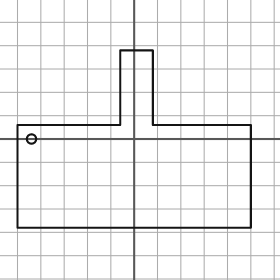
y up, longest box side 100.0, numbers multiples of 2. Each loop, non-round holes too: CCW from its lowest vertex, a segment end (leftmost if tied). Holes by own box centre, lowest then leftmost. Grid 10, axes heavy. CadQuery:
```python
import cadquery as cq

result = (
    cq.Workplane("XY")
    .moveTo(-50.0, -38.0)
    .lineTo(50.0, -38.0)
    .lineTo(50.0, 6.0)
    .lineTo(8.0, 6.0)
    .lineTo(8.0, 38.0)
    .lineTo(-6.0, 38.0)
    .lineTo(-6.0, 6.0)
    .lineTo(-50.0, 6.0)
    .close()
    .moveTo(-44.0, 0.0)
    .circle(2.0)
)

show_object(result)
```